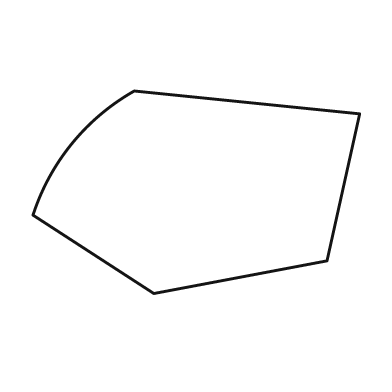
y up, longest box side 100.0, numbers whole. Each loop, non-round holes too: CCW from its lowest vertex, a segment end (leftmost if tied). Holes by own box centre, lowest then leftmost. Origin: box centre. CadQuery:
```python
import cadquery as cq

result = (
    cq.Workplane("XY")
    .moveTo(-13.0, -31.0)
    .lineTo(40.0, -21.0)
    .lineTo(50.0, 24.0)
    .lineTo(-19.0, 31.0)
    .threePointArc((-38.0, 15.0), (-50.0, -7.0))
    .close()
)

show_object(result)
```